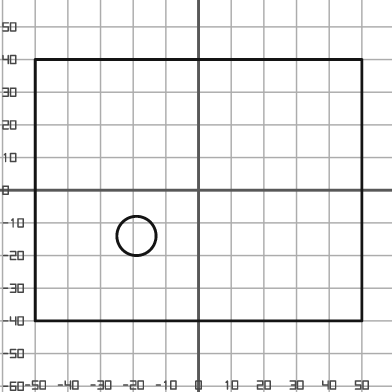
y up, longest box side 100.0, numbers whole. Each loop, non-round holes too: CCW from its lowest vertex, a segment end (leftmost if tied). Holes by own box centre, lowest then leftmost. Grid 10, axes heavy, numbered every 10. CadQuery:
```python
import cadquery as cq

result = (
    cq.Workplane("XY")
    .moveTo(-50.0, -40.0)
    .lineTo(50.0, -40.0)
    .lineTo(50.0, 40.0)
    .lineTo(-50.0, 40.0)
    .close()
    .moveTo(-19.0, -14.0)
    .circle(6.0)
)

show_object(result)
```